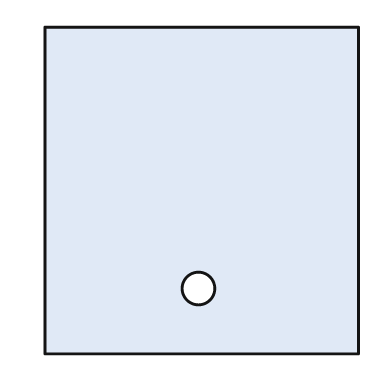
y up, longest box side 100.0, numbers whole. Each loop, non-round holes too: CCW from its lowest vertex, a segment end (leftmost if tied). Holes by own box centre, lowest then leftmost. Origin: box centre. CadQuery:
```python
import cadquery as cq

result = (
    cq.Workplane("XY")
    .moveTo(-48.0, -50.0)
    .lineTo(48.0, -50.0)
    .lineTo(48.0, 50.0)
    .lineTo(-48.0, 50.0)
    .close()
    .moveTo(-1.0, -30.0)
    .circle(5.0)
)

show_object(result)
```